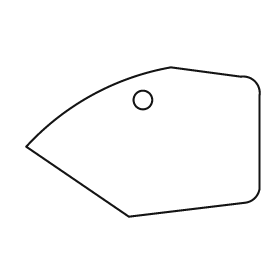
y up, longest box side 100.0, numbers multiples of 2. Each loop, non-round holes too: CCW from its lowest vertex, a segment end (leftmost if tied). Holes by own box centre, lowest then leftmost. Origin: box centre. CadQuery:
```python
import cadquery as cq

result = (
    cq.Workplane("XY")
    .moveTo(-6.0, -32.0)
    .lineTo(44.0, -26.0)
    .threePointArc((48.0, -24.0), (50.0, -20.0))
    .lineTo(50.0, 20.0)
    .threePointArc((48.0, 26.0), (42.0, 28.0))
    .lineTo(12.0, 32.0)
    .threePointArc((-22.0, 20.0), (-50.0, -2.0))
    .close()
    .moveTo(0.0, 18.0)
    .circle(4.0)
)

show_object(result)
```